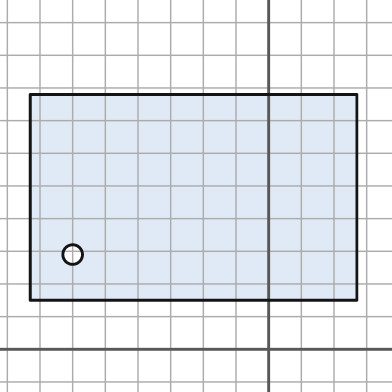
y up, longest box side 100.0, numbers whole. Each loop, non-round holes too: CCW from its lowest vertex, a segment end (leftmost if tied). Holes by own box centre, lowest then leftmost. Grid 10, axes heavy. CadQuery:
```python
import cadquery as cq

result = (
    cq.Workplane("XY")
    .moveTo(-73.0, 15.0)
    .lineTo(27.0, 15.0)
    .lineTo(27.0, 78.0)
    .lineTo(-73.0, 78.0)
    .close()
    .moveTo(-60.0, 29.0)
    .circle(3.0)
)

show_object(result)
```